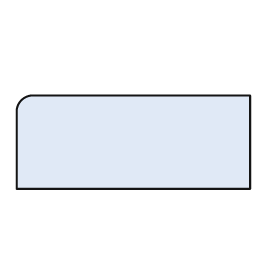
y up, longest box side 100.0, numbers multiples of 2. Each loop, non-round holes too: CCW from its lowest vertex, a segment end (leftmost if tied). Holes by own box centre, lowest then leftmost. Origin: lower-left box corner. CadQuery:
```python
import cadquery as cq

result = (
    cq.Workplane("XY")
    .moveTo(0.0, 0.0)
    .lineTo(100.0, 0.0)
    .lineTo(100.0, 40.0)
    .lineTo(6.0, 40.0)
    .threePointArc((2.0, 38.0), (0.0, 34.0))
    .close()
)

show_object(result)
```